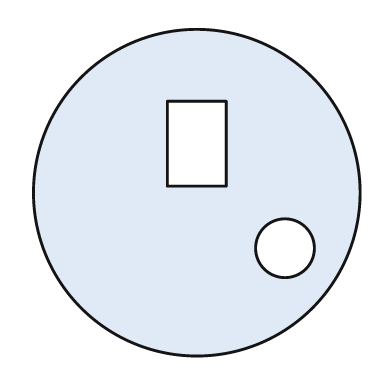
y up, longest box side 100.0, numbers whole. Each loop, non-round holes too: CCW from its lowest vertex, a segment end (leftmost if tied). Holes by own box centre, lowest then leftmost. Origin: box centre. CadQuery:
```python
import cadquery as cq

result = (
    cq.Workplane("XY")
    .moveTo(0.0, 0.0)
    .circle(50.0)
    .moveTo(27.0, -17.0)
    .circle(9.0)
    .moveTo(-9.0, 2.0)
    .lineTo(9.0, 2.0)
    .lineTo(9.0, 28.0)
    .lineTo(-9.0, 28.0)
    .close()
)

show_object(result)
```